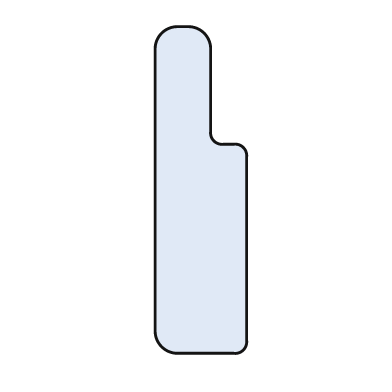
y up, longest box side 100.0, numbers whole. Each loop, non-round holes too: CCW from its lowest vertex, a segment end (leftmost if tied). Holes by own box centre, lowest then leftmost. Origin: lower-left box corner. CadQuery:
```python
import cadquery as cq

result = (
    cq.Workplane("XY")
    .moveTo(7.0, 0.0)
    .lineTo(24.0, 0.0)
    .threePointArc((27.0, 1.0), (28.0, 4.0))
    .lineTo(28.0, 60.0)
    .threePointArc((27.0, 63.0), (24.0, 64.0))
    .lineTo(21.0, 64.0)
    .threePointArc((18.0, 65.0), (17.0, 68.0))
    .lineTo(17.0, 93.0)
    .threePointArc((15.0, 98.0), (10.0, 100.0))
    .lineTo(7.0, 100.0)
    .threePointArc((2.0, 98.0), (0.0, 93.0))
    .lineTo(0.0, 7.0)
    .threePointArc((2.0, 2.0), (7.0, 0.0))
    .close()
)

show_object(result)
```